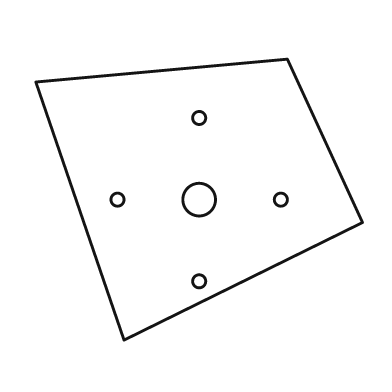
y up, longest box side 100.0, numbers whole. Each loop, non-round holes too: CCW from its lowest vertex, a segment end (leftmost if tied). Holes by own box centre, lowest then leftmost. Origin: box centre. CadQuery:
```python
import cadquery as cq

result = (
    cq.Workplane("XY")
    .moveTo(-23.0, -43.0)
    .lineTo(50.0, -7.0)
    .lineTo(27.0, 43.0)
    .lineTo(-50.0, 36.0)
    .close()
    .moveTo(0.0, -25.0)
    .circle(2.0)
    .moveTo(-25.0, 0.0)
    .circle(2.0)
    .moveTo(0.0, 0.0)
    .circle(5.0)
    .moveTo(25.0, 0.0)
    .circle(2.0)
    .moveTo(0.0, 25.0)
    .circle(2.0)
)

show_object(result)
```